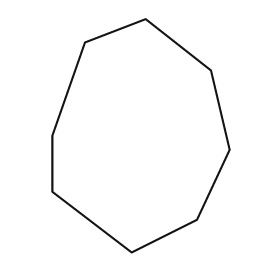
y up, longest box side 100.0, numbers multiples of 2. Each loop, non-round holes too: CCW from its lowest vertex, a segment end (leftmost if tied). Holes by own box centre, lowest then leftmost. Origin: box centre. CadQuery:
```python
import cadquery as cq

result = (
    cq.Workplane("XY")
    .moveTo(-4.0, -50.0)
    .lineTo(24.0, -36.0)
    .lineTo(38.0, -6.0)
    .lineTo(30.0, 28.0)
    .lineTo(2.0, 50.0)
    .lineTo(-24.0, 40.0)
    .lineTo(-38.0, 0.0)
    .lineTo(-38.0, -24.0)
    .close()
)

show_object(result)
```